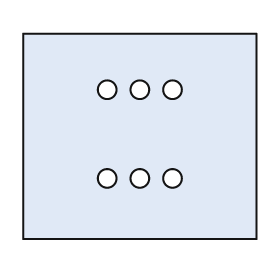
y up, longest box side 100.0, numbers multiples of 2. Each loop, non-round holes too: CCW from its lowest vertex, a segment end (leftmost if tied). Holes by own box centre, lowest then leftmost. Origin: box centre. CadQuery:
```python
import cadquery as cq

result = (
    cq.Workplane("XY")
    .moveTo(-50.0, -44.0)
    .lineTo(50.0, -44.0)
    .lineTo(50.0, 44.0)
    .lineTo(-50.0, 44.0)
    .close()
    .moveTo(-14.0, -18.0)
    .circle(4.0)
    .moveTo(0.0, -18.0)
    .circle(4.0)
    .moveTo(14.0, -18.0)
    .circle(4.0)
    .moveTo(-14.0, 20.0)
    .circle(4.0)
    .moveTo(0.0, 20.0)
    .circle(4.0)
    .moveTo(14.0, 20.0)
    .circle(4.0)
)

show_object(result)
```